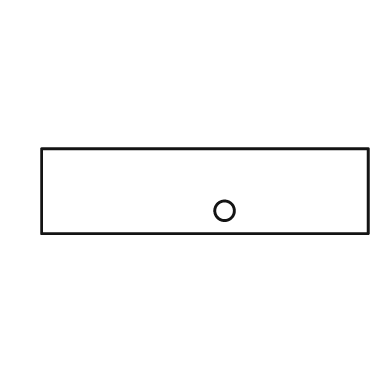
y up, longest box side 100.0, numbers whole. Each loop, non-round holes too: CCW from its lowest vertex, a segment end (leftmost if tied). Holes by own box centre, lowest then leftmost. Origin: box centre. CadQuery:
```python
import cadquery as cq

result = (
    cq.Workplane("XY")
    .moveTo(-50.0, -13.0)
    .lineTo(50.0, -13.0)
    .lineTo(50.0, 13.0)
    .lineTo(-50.0, 13.0)
    .close()
    .moveTo(6.0, -6.0)
    .circle(3.0)
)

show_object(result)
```